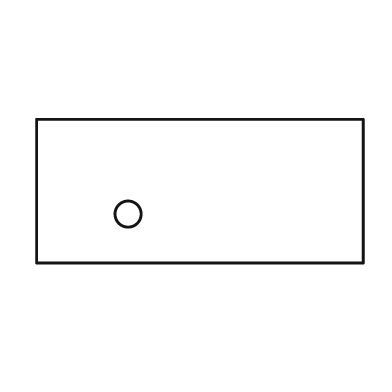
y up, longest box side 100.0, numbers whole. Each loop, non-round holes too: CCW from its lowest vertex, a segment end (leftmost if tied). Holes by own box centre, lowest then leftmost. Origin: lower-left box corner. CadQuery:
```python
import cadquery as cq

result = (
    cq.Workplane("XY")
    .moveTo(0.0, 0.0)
    .lineTo(100.0, 0.0)
    .lineTo(100.0, 44.0)
    .lineTo(0.0, 44.0)
    .close()
    .moveTo(28.0, 15.0)
    .circle(4.0)
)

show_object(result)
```